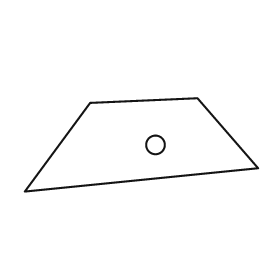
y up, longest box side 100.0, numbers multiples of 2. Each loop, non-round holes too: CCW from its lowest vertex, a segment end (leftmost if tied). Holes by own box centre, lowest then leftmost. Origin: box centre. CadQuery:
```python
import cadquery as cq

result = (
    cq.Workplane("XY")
    .moveTo(-50.0, -20.0)
    .lineTo(50.0, -10.0)
    .lineTo(24.0, 20.0)
    .lineTo(-22.0, 18.0)
    .close()
    .moveTo(6.0, 0.0)
    .circle(4.0)
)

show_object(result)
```